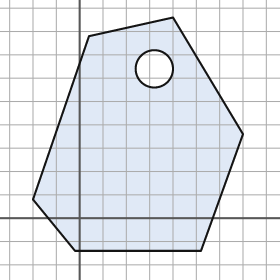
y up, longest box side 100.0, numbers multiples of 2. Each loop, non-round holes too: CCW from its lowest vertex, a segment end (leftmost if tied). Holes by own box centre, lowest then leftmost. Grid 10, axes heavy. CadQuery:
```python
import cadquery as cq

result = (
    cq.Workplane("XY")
    .moveTo(-2.0, -14.0)
    .lineTo(52.0, -14.0)
    .lineTo(70.0, 36.0)
    .lineTo(40.0, 86.0)
    .lineTo(4.0, 78.0)
    .lineTo(-20.0, 8.0)
    .close()
    .moveTo(32.0, 64.0)
    .circle(8.0)
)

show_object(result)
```